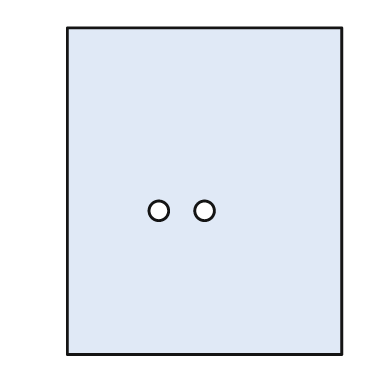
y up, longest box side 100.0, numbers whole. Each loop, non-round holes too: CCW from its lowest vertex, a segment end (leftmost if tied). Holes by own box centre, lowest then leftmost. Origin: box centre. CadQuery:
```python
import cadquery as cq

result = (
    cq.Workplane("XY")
    .moveTo(-42.0, -50.0)
    .lineTo(42.0, -50.0)
    .lineTo(42.0, 50.0)
    .lineTo(-42.0, 50.0)
    .close()
    .moveTo(-14.0, -6.0)
    .circle(3.0)
    .moveTo(0.0, -6.0)
    .circle(3.0)
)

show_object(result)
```